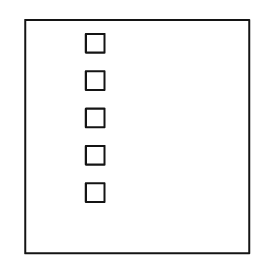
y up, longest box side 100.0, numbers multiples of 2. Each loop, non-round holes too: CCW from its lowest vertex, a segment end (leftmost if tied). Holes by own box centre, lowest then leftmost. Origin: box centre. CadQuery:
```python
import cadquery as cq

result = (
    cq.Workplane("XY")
    .moveTo(-48.0, -50.0)
    .lineTo(48.0, -50.0)
    .lineTo(48.0, 50.0)
    .lineTo(-48.0, 50.0)
    .close()
    .moveTo(-22.0, -28.0)
    .lineTo(-14.0, -28.0)
    .lineTo(-14.0, -20.0)
    .lineTo(-22.0, -20.0)
    .close()
    .moveTo(-22.0, -12.0)
    .lineTo(-14.0, -12.0)
    .lineTo(-14.0, -4.0)
    .lineTo(-22.0, -4.0)
    .close()
    .moveTo(-22.0, 4.0)
    .lineTo(-14.0, 4.0)
    .lineTo(-14.0, 12.0)
    .lineTo(-22.0, 12.0)
    .close()
    .moveTo(-22.0, 20.0)
    .lineTo(-14.0, 20.0)
    .lineTo(-14.0, 28.0)
    .lineTo(-22.0, 28.0)
    .close()
    .moveTo(-22.0, 36.0)
    .lineTo(-14.0, 36.0)
    .lineTo(-14.0, 44.0)
    .lineTo(-22.0, 44.0)
    .close()
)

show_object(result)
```